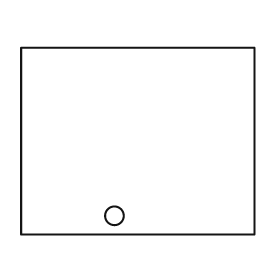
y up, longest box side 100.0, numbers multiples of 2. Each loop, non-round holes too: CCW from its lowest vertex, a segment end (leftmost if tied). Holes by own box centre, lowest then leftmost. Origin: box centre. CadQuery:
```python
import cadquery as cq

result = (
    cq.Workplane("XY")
    .moveTo(-50.0, -40.0)
    .lineTo(50.0, -40.0)
    .lineTo(50.0, 40.0)
    .lineTo(-50.0, 40.0)
    .close()
    .moveTo(-10.0, -32.0)
    .circle(4.0)
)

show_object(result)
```